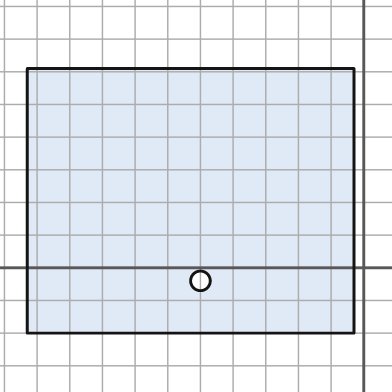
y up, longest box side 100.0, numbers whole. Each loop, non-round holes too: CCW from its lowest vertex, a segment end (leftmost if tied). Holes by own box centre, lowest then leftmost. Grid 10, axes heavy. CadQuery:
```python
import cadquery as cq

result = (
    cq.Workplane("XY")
    .moveTo(-103.0, -20.0)
    .lineTo(-3.0, -20.0)
    .lineTo(-3.0, 61.0)
    .lineTo(-103.0, 61.0)
    .close()
    .moveTo(-50.0, -4.0)
    .circle(3.0)
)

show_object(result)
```